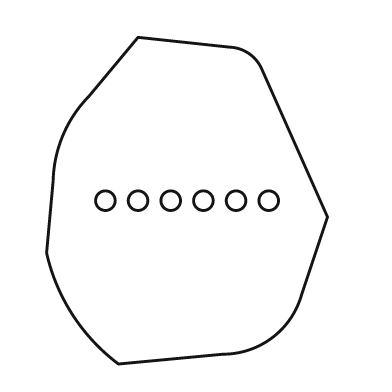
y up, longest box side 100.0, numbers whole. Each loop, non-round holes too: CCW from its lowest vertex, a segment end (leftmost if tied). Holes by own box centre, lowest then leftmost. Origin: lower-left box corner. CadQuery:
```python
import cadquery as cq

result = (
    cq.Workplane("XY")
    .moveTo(22.0, 0.0)
    .lineTo(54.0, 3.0)
    .threePointArc((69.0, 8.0), (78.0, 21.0))
    .lineTo(86.0, 45.0)
    .lineTo(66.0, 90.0)
    .threePointArc((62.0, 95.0), (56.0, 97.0))
    .lineTo(28.0, 100.0)
    .lineTo(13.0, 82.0)
    .threePointArc((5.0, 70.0), (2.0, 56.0))
    .lineTo(0.0, 34.0)
    .threePointArc((8.0, 15.0), (22.0, 0.0))
    .close()
    .moveTo(18.0, 50.0)
    .circle(3.0)
    .moveTo(28.0, 50.0)
    .circle(3.0)
    .moveTo(38.0, 50.0)
    .circle(3.0)
    .moveTo(48.0, 50.0)
    .circle(3.0)
    .moveTo(58.0, 50.0)
    .circle(3.0)
    .moveTo(68.0, 50.0)
    .circle(3.0)
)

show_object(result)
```